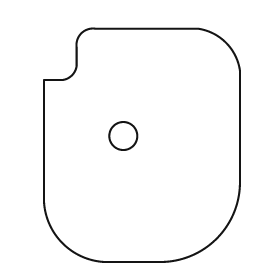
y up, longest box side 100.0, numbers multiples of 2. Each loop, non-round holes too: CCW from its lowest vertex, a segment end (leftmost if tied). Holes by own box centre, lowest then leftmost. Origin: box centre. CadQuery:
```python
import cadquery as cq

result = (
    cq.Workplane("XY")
    .moveTo(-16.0, -50.0)
    .lineTo(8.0, -50.0)
    .threePointArc((32.0, -40.0), (42.0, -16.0))
    .lineTo(42.0, 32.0)
    .threePointArc((36.0, 44.0), (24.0, 50.0))
    .lineTo(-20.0, 50.0)
    .threePointArc((-26.0, 48.0), (-28.0, 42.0))
    .lineTo(-28.0, 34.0)
    .threePointArc((-30.0, 30.0), (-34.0, 28.0))
    .lineTo(-42.0, 28.0)
    .lineTo(-42.0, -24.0)
    .threePointArc((-34.0, -42.0), (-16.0, -50.0))
    .close()
    .moveTo(-8.0, 4.0)
    .circle(6.0)
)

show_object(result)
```